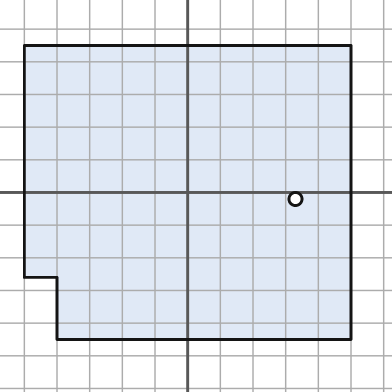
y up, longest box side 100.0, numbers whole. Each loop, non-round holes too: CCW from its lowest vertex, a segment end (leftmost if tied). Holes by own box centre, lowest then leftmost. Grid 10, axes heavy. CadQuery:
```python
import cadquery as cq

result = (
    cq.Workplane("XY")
    .moveTo(-40.0, -45.0)
    .lineTo(50.0, -45.0)
    .lineTo(50.0, 45.0)
    .lineTo(-50.0, 45.0)
    .lineTo(-50.0, -26.0)
    .lineTo(-40.0, -26.0)
    .close()
    .moveTo(33.0, -2.0)
    .circle(2.0)
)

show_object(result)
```